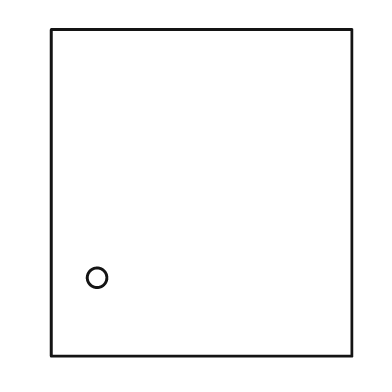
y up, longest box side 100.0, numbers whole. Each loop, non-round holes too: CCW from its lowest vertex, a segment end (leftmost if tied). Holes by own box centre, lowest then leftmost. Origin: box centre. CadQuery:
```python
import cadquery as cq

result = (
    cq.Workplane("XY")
    .moveTo(-46.0, -50.0)
    .lineTo(46.0, -50.0)
    .lineTo(46.0, 50.0)
    .lineTo(-46.0, 50.0)
    .close()
    .moveTo(-32.0, -26.0)
    .circle(3.0)
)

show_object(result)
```